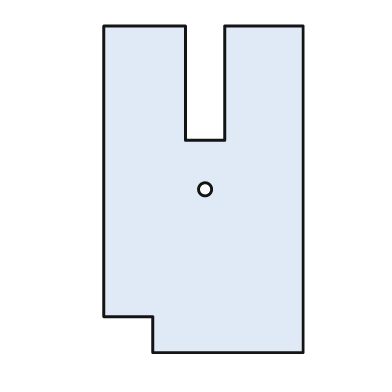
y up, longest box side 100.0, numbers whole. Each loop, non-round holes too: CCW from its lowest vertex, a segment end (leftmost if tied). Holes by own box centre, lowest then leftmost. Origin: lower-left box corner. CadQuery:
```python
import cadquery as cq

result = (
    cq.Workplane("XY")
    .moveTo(15.0, 0.0)
    .lineTo(61.0, 0.0)
    .lineTo(61.0, 100.0)
    .lineTo(37.0, 100.0)
    .lineTo(37.0, 65.0)
    .lineTo(25.0, 65.0)
    .lineTo(25.0, 100.0)
    .lineTo(0.0, 100.0)
    .lineTo(0.0, 11.0)
    .lineTo(15.0, 11.0)
    .close()
    .moveTo(31.0, 50.0)
    .circle(2.0)
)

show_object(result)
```